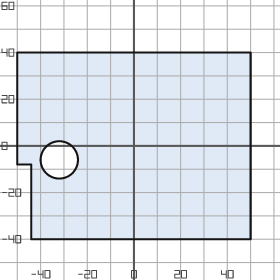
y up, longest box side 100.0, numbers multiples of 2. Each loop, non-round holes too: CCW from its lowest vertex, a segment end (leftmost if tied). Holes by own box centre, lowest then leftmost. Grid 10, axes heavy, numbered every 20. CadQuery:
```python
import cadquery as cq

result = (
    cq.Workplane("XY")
    .moveTo(-44.0, -40.0)
    .lineTo(50.0, -40.0)
    .lineTo(50.0, 40.0)
    .lineTo(-50.0, 40.0)
    .lineTo(-50.0, -8.0)
    .lineTo(-44.0, -8.0)
    .close()
    .moveTo(-32.0, -6.0)
    .circle(8.0)
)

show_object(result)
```